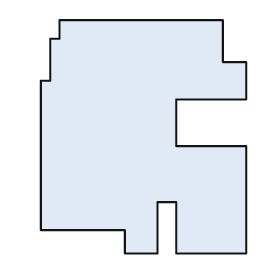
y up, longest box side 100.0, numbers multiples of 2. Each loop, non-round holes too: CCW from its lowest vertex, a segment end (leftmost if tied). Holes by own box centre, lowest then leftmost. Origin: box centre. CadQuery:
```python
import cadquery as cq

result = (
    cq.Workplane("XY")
    .moveTo(-8.0, -50.0)
    .lineTo(6.0, -50.0)
    .lineTo(6.0, -28.0)
    .lineTo(14.0, -28.0)
    .lineTo(14.0, -50.0)
    .lineTo(44.0, -50.0)
    .lineTo(44.0, -4.0)
    .lineTo(14.0, -4.0)
    .lineTo(14.0, 16.0)
    .lineTo(44.0, 16.0)
    .lineTo(44.0, 32.0)
    .lineTo(34.0, 32.0)
    .lineTo(34.0, 50.0)
    .lineTo(-36.0, 50.0)
    .lineTo(-36.0, 42.0)
    .lineTo(-40.0, 42.0)
    .lineTo(-40.0, 24.0)
    .lineTo(-44.0, 24.0)
    .lineTo(-44.0, -40.0)
    .lineTo(-8.0, -40.0)
    .close()
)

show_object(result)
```